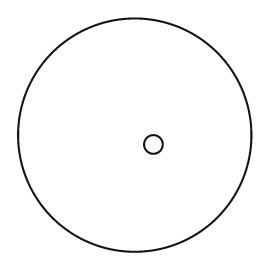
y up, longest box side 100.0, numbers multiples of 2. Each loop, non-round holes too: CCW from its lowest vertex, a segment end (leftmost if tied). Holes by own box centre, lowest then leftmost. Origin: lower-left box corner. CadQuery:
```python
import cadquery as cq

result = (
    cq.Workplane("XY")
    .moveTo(50.0, 50.0)
    .circle(50.0)
    .moveTo(58.0, 46.0)
    .circle(4.0)
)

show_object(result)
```